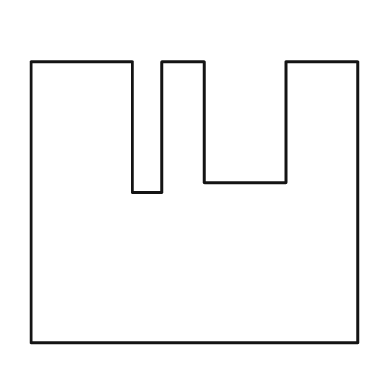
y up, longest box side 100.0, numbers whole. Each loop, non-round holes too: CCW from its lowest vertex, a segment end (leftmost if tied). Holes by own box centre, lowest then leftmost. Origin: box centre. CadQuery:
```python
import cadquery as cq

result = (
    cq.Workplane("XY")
    .moveTo(-50.0, -43.0)
    .lineTo(50.0, -43.0)
    .lineTo(50.0, 43.0)
    .lineTo(28.0, 43.0)
    .lineTo(28.0, 6.0)
    .lineTo(3.0, 6.0)
    .lineTo(3.0, 43.0)
    .lineTo(-10.0, 43.0)
    .lineTo(-10.0, 3.0)
    .lineTo(-19.0, 3.0)
    .lineTo(-19.0, 43.0)
    .lineTo(-50.0, 43.0)
    .close()
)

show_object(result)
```